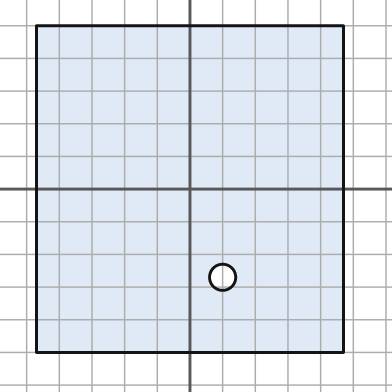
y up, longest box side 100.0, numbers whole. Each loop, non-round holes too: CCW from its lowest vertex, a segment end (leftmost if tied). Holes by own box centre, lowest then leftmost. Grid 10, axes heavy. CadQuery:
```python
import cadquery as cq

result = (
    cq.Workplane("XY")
    .moveTo(-47.0, -50.0)
    .lineTo(47.0, -50.0)
    .lineTo(47.0, 50.0)
    .lineTo(-47.0, 50.0)
    .close()
    .moveTo(10.0, -27.0)
    .circle(4.0)
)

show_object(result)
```